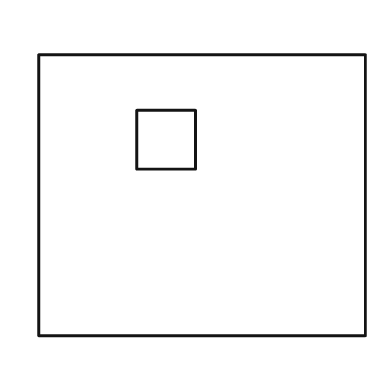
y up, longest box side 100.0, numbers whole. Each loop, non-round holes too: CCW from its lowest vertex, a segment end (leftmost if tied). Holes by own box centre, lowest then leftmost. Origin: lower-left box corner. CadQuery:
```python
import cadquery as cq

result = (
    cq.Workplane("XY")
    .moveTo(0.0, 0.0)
    .lineTo(100.0, 0.0)
    .lineTo(100.0, 86.0)
    .lineTo(0.0, 86.0)
    .close()
    .moveTo(30.0, 51.0)
    .lineTo(48.0, 51.0)
    .lineTo(48.0, 69.0)
    .lineTo(30.0, 69.0)
    .close()
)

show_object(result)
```